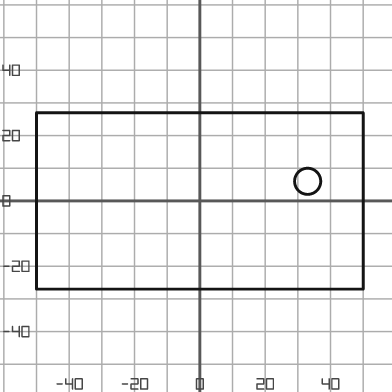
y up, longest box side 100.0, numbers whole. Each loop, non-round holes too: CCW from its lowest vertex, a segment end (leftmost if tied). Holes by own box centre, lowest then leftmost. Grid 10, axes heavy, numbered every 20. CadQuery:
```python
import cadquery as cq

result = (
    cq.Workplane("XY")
    .moveTo(-50.0, -27.0)
    .lineTo(50.0, -27.0)
    .lineTo(50.0, 27.0)
    .lineTo(-50.0, 27.0)
    .close()
    .moveTo(33.0, 6.0)
    .circle(4.0)
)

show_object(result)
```